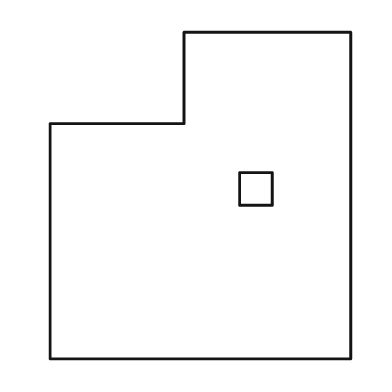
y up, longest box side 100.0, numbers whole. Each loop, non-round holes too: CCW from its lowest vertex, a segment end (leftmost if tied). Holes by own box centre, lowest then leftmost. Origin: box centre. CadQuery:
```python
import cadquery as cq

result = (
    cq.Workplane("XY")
    .moveTo(-46.0, -50.0)
    .lineTo(46.0, -50.0)
    .lineTo(46.0, 50.0)
    .lineTo(-5.0, 50.0)
    .lineTo(-5.0, 22.0)
    .lineTo(-46.0, 22.0)
    .close()
    .moveTo(12.0, -3.0)
    .lineTo(22.0, -3.0)
    .lineTo(22.0, 7.0)
    .lineTo(12.0, 7.0)
    .close()
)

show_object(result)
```